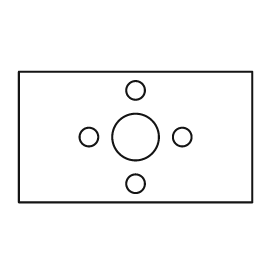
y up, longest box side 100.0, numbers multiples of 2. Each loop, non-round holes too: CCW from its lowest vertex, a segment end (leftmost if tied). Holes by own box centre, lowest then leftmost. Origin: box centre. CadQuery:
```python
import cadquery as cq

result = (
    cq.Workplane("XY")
    .moveTo(-50.0, -28.0)
    .lineTo(50.0, -28.0)
    .lineTo(50.0, 28.0)
    .lineTo(-50.0, 28.0)
    .close()
    .moveTo(0.0, -20.0)
    .circle(4.0)
    .moveTo(-20.0, 0.0)
    .circle(4.0)
    .moveTo(0.0, 0.0)
    .circle(10.0)
    .moveTo(20.0, 0.0)
    .circle(4.0)
    .moveTo(0.0, 20.0)
    .circle(4.0)
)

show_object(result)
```